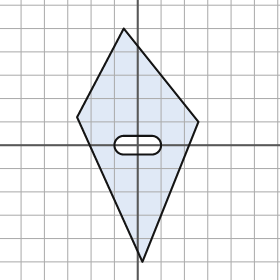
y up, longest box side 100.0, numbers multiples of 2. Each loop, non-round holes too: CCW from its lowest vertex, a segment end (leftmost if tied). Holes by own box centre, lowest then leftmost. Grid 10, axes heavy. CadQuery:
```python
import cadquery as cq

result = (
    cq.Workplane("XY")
    .moveTo(2.0, -50.0)
    .lineTo(26.0, 10.0)
    .lineTo(-6.0, 50.0)
    .lineTo(-26.0, 12.0)
    .close()
    .moveTo(-6.0, -4.0)
    .lineTo(6.0, -4.0)
    .threePointArc((10.0, 0.0), (6.0, 4.0))
    .lineTo(-6.0, 4.0)
    .threePointArc((-10.0, 0.0), (-6.0, -4.0))
    .close()
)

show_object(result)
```